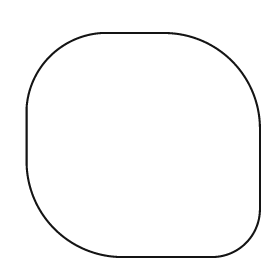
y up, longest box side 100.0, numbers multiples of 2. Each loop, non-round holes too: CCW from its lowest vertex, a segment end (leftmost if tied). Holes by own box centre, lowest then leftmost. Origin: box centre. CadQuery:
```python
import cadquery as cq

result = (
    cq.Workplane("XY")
    .moveTo(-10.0, -48.0)
    .lineTo(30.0, -48.0)
    .threePointArc((44.0, -42.0), (50.0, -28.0))
    .lineTo(50.0, 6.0)
    .threePointArc((38.0, 36.0), (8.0, 48.0))
    .lineTo(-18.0, 48.0)
    .threePointArc((-40.0, 38.0), (-50.0, 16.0))
    .lineTo(-50.0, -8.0)
    .threePointArc((-38.0, -36.0), (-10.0, -48.0))
    .close()
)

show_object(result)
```